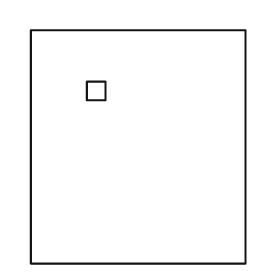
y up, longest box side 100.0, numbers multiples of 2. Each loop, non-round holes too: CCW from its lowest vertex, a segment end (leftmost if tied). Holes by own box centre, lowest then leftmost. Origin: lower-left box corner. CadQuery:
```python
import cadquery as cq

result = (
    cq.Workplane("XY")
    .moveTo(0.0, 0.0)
    .lineTo(92.0, 0.0)
    .lineTo(92.0, 100.0)
    .lineTo(0.0, 100.0)
    .close()
    .moveTo(24.0, 70.0)
    .lineTo(32.0, 70.0)
    .lineTo(32.0, 78.0)
    .lineTo(24.0, 78.0)
    .close()
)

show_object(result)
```